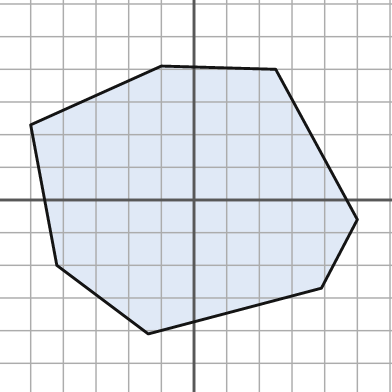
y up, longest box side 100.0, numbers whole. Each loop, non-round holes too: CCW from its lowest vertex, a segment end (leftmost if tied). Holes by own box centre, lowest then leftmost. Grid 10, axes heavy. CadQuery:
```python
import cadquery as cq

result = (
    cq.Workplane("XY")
    .moveTo(-14.0, -41.0)
    .lineTo(39.0, -27.0)
    .lineTo(50.0, -6.0)
    .lineTo(25.0, 40.0)
    .lineTo(-10.0, 41.0)
    .lineTo(-50.0, 23.0)
    .lineTo(-42.0, -20.0)
    .close()
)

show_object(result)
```